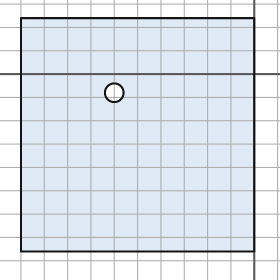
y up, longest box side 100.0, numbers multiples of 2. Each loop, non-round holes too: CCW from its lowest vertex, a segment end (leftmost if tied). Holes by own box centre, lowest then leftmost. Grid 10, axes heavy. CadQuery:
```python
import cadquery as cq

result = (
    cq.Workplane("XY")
    .moveTo(-100.0, -76.0)
    .lineTo(0.0, -76.0)
    .lineTo(0.0, 24.0)
    .lineTo(-100.0, 24.0)
    .close()
    .moveTo(-60.0, -8.0)
    .circle(4.0)
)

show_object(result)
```